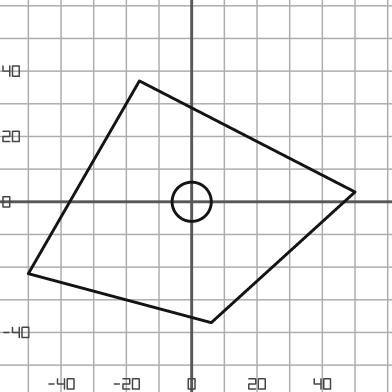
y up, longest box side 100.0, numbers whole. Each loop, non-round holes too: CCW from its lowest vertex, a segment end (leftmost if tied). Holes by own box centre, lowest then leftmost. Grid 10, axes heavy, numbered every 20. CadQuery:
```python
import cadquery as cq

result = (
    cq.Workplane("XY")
    .moveTo(6.0, -37.0)
    .lineTo(50.0, 3.0)
    .lineTo(-16.0, 37.0)
    .lineTo(-50.0, -22.0)
    .close()
    .moveTo(0.0, 0.0)
    .circle(6.0)
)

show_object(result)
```